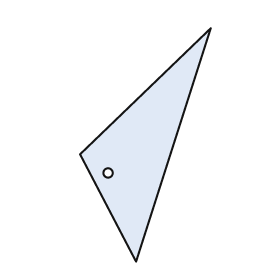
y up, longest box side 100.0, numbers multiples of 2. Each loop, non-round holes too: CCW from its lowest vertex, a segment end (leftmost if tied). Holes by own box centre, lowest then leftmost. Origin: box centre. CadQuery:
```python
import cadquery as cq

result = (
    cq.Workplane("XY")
    .moveTo(-4.0, -50.0)
    .lineTo(28.0, 50.0)
    .lineTo(-28.0, -4.0)
    .close()
    .moveTo(-16.0, -12.0)
    .circle(2.0)
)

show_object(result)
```